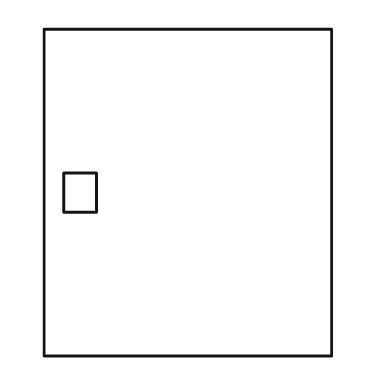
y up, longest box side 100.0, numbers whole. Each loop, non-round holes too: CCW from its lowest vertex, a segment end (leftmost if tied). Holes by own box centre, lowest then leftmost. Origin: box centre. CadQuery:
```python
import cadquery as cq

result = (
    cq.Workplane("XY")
    .moveTo(-44.0, -50.0)
    .lineTo(44.0, -50.0)
    .lineTo(44.0, 50.0)
    .lineTo(-44.0, 50.0)
    .close()
    .moveTo(-38.0, -6.0)
    .lineTo(-28.0, -6.0)
    .lineTo(-28.0, 6.0)
    .lineTo(-38.0, 6.0)
    .close()
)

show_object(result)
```